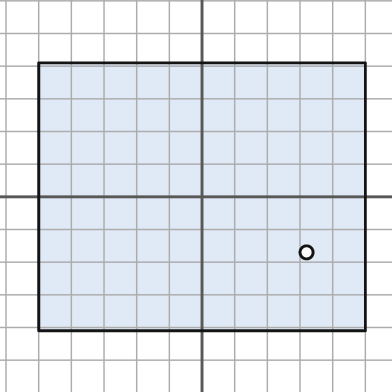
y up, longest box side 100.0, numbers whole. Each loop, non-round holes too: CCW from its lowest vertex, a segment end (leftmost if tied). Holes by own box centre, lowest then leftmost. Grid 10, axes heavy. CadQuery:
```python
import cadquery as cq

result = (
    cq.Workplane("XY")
    .moveTo(-50.0, -41.0)
    .lineTo(50.0, -41.0)
    .lineTo(50.0, 41.0)
    .lineTo(-50.0, 41.0)
    .close()
    .moveTo(32.0, -17.0)
    .circle(2.0)
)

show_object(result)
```